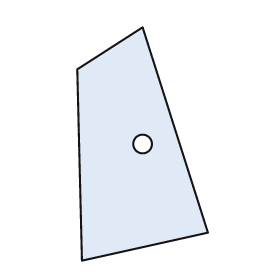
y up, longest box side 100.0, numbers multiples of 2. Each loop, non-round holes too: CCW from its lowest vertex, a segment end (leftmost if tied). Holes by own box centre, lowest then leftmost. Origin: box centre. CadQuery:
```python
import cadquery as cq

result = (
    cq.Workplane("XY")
    .moveTo(-26.0, -50.0)
    .lineTo(28.0, -38.0)
    .lineTo(0.0, 50.0)
    .lineTo(-28.0, 32.0)
    .close()
    .moveTo(0.0, 0.0)
    .circle(4.0)
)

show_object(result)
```